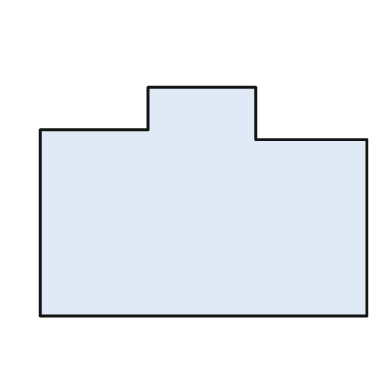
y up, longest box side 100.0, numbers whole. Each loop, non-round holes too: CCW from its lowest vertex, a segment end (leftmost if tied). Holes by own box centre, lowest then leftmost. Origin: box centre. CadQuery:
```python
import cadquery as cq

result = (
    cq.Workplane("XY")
    .moveTo(-50.0, -35.0)
    .lineTo(50.0, -35.0)
    .lineTo(50.0, 19.0)
    .lineTo(16.0, 19.0)
    .lineTo(16.0, 35.0)
    .lineTo(-17.0, 35.0)
    .lineTo(-17.0, 22.0)
    .lineTo(-50.0, 22.0)
    .close()
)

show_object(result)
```